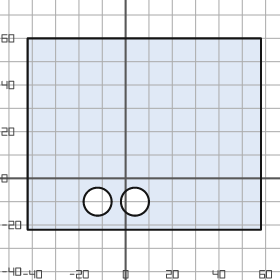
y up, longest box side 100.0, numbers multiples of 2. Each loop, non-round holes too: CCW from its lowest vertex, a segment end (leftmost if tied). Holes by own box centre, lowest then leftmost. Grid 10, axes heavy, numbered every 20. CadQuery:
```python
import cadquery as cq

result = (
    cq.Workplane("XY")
    .moveTo(-42.0, -22.0)
    .lineTo(58.0, -22.0)
    .lineTo(58.0, 60.0)
    .lineTo(-42.0, 60.0)
    .close()
    .moveTo(-12.0, -10.0)
    .circle(6.0)
    .moveTo(4.0, -10.0)
    .circle(6.0)
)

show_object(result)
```